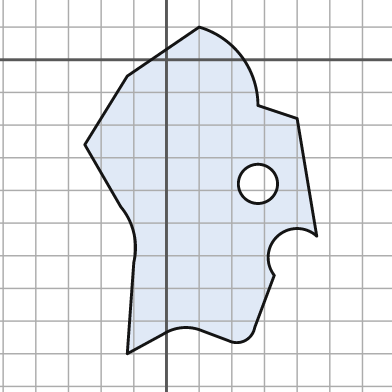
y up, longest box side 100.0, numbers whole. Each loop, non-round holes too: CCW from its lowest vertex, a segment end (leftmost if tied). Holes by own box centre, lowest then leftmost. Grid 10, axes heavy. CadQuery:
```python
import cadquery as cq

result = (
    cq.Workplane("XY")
    .moveTo(-12.0, -90.0)
    .lineTo(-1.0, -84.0)
    .threePointArc((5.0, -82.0), (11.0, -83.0))
    .lineTo(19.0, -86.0)
    .threePointArc((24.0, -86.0), (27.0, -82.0))
    .lineTo(33.0, -66.0)
    .threePointArc((34.0, -54.0), (46.0, -54.0))
    .lineTo(40.0, -18.0)
    .lineTo(28.0, -14.0)
    .threePointArc((23.0, 1.0), (10.0, 10.0))
    .lineTo(-12.0, -5.0)
    .lineTo(-25.0, -26.0)
    .lineTo(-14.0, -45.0)
    .threePointArc((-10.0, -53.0), (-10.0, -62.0))
    .close()
    .moveTo(28.0, -38.0)
    .circle(6.0)
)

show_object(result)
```